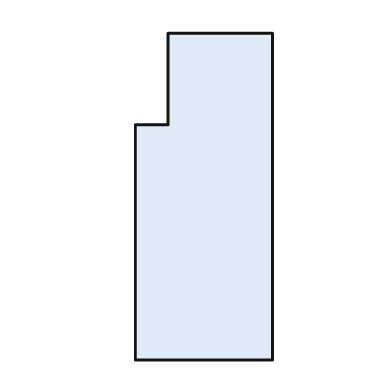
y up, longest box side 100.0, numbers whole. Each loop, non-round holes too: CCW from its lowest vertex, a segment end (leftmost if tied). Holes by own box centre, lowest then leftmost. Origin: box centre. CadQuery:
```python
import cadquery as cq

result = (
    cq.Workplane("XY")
    .moveTo(-21.0, -50.0)
    .lineTo(21.0, -50.0)
    .lineTo(21.0, 50.0)
    .lineTo(-11.0, 50.0)
    .lineTo(-11.0, 22.0)
    .lineTo(-21.0, 22.0)
    .close()
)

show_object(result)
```